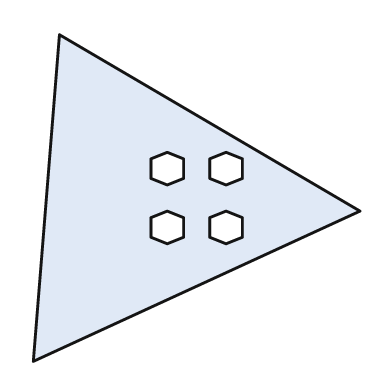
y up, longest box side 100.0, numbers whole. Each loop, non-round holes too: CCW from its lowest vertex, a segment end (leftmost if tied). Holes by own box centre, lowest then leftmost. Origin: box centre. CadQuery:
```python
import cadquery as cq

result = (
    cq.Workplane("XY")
    .moveTo(-50.0, -50.0)
    .lineTo(50.0, -4.0)
    .lineTo(-42.0, 50.0)
    .close()
    .moveTo(-9.0, -14.0)
    .lineTo(-4.0, -12.0)
    .lineTo(-4.0, -6.0)
    .lineTo(-9.0, -4.0)
    .lineTo(-14.0, -6.0)
    .lineTo(-14.0, -12.0)
    .close()
    .moveTo(9.0, -14.0)
    .lineTo(14.0, -12.0)
    .lineTo(14.0, -6.0)
    .lineTo(9.0, -4.0)
    .lineTo(4.0, -6.0)
    .lineTo(4.0, -12.0)
    .close()
    .moveTo(-9.0, 4.0)
    .lineTo(-4.0, 6.0)
    .lineTo(-4.0, 12.0)
    .lineTo(-9.0, 14.0)
    .lineTo(-14.0, 12.0)
    .lineTo(-14.0, 6.0)
    .close()
    .moveTo(9.0, 4.0)
    .lineTo(14.0, 6.0)
    .lineTo(14.0, 12.0)
    .lineTo(9.0, 14.0)
    .lineTo(4.0, 12.0)
    .lineTo(4.0, 6.0)
    .close()
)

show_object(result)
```